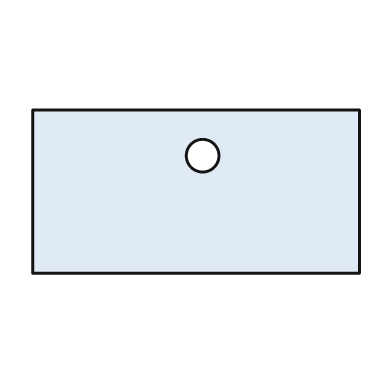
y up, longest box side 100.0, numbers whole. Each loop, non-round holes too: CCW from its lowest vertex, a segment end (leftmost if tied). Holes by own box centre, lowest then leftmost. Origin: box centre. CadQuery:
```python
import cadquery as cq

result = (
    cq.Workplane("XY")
    .moveTo(-50.0, -25.0)
    .lineTo(50.0, -25.0)
    .lineTo(50.0, 25.0)
    .lineTo(-50.0, 25.0)
    .close()
    .moveTo(2.0, 11.0)
    .circle(5.0)
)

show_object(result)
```